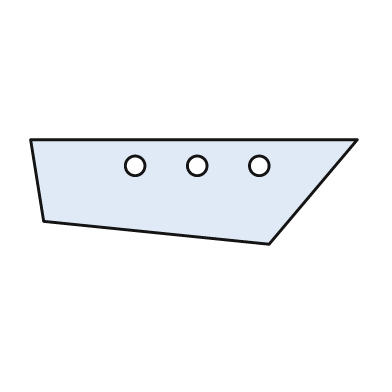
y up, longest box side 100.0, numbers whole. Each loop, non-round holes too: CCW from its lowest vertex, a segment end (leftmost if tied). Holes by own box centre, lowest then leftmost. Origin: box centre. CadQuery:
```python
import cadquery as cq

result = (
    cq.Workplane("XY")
    .moveTo(23.0, -16.0)
    .lineTo(50.0, 16.0)
    .lineTo(-50.0, 16.0)
    .lineTo(-46.0, -9.0)
    .close()
    .moveTo(-18.0, 8.0)
    .circle(3.0)
    .moveTo(1.0, 8.0)
    .circle(3.0)
    .moveTo(20.0, 8.0)
    .circle(3.0)
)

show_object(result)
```